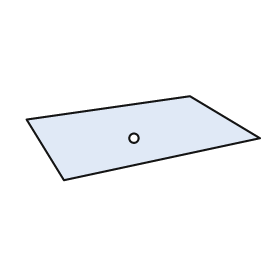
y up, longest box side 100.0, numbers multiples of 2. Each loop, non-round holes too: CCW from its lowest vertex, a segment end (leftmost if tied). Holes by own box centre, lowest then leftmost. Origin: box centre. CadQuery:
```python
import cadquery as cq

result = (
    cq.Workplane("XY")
    .moveTo(-34.0, -18.0)
    .lineTo(50.0, 0.0)
    .lineTo(20.0, 18.0)
    .lineTo(-50.0, 8.0)
    .close()
    .moveTo(-4.0, 0.0)
    .circle(2.0)
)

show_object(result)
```